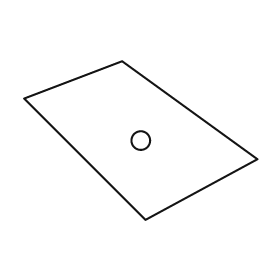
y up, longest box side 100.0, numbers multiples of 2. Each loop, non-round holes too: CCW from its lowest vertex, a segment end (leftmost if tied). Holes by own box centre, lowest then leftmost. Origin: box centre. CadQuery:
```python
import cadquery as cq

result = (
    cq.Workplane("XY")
    .moveTo(2.0, -34.0)
    .lineTo(50.0, -8.0)
    .lineTo(-8.0, 34.0)
    .lineTo(-50.0, 18.0)
    .close()
    .moveTo(0.0, 0.0)
    .circle(4.0)
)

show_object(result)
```